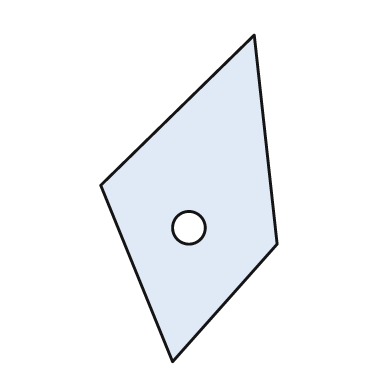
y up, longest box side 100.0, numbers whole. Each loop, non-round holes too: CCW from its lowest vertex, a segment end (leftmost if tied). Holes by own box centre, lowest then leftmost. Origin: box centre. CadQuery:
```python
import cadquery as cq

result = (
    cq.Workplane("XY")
    .moveTo(-5.0, -50.0)
    .lineTo(27.0, -14.0)
    .lineTo(20.0, 50.0)
    .lineTo(-27.0, 4.0)
    .close()
    .moveTo(0.0, -9.0)
    .circle(5.0)
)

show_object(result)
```